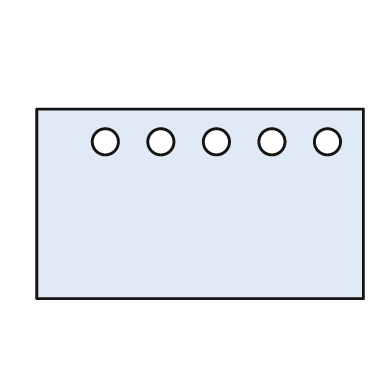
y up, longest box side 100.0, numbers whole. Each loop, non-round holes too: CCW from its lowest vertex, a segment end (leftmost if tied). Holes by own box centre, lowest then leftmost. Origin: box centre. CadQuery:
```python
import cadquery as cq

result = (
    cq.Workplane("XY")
    .moveTo(-50.0, -29.0)
    .lineTo(50.0, -29.0)
    .lineTo(50.0, 29.0)
    .lineTo(-50.0, 29.0)
    .close()
    .moveTo(-29.0, 19.0)
    .circle(4.0)
    .moveTo(-12.0, 19.0)
    .circle(4.0)
    .moveTo(5.0, 19.0)
    .circle(4.0)
    .moveTo(22.0, 19.0)
    .circle(4.0)
    .moveTo(39.0, 19.0)
    .circle(4.0)
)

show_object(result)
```